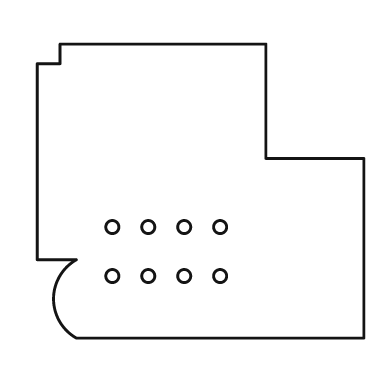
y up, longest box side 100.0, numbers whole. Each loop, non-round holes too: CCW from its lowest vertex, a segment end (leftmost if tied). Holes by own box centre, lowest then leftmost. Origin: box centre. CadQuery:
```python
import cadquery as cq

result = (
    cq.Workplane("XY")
    .moveTo(-38.0, -45.0)
    .lineTo(50.0, -45.0)
    .lineTo(50.0, 10.0)
    .lineTo(20.0, 10.0)
    .lineTo(20.0, 45.0)
    .lineTo(-43.0, 45.0)
    .lineTo(-43.0, 39.0)
    .lineTo(-50.0, 39.0)
    .lineTo(-50.0, -21.0)
    .lineTo(-38.0, -21.0)
    .threePointArc((-45.0, -33.0), (-38.0, -45.0))
    .close()
    .moveTo(-27.0, -26.0)
    .circle(2.0)
    .moveTo(-16.0, -26.0)
    .circle(2.0)
    .moveTo(-5.0, -26.0)
    .circle(2.0)
    .moveTo(6.0, -26.0)
    .circle(2.0)
    .moveTo(-27.0, -11.0)
    .circle(2.0)
    .moveTo(-16.0, -11.0)
    .circle(2.0)
    .moveTo(-5.0, -11.0)
    .circle(2.0)
    .moveTo(6.0, -11.0)
    .circle(2.0)
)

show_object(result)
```